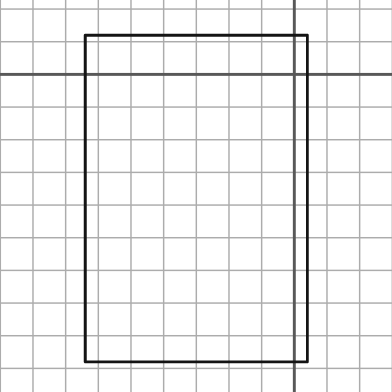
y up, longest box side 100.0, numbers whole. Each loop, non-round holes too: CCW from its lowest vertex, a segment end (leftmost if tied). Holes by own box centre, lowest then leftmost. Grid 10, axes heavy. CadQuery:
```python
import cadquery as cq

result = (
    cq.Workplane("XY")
    .moveTo(-64.0, -88.0)
    .lineTo(4.0, -88.0)
    .lineTo(4.0, 12.0)
    .lineTo(-64.0, 12.0)
    .close()
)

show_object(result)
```